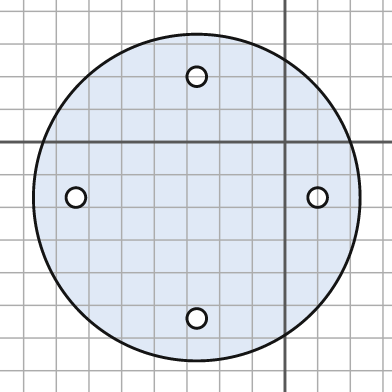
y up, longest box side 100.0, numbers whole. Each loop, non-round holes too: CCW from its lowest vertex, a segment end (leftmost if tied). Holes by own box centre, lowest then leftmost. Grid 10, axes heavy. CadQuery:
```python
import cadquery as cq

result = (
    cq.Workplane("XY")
    .moveTo(-27.0, -17.0)
    .circle(50.0)
    .moveTo(-27.0, -54.0)
    .circle(3.0)
    .moveTo(-64.0, -17.0)
    .circle(3.0)
    .moveTo(10.0, -17.0)
    .circle(3.0)
    .moveTo(-27.0, 20.0)
    .circle(3.0)
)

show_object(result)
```